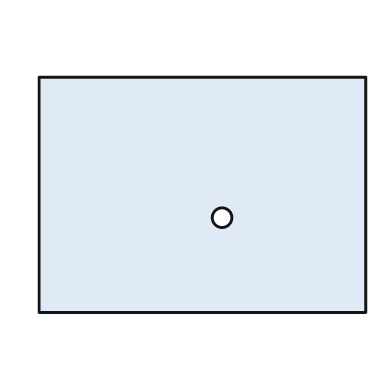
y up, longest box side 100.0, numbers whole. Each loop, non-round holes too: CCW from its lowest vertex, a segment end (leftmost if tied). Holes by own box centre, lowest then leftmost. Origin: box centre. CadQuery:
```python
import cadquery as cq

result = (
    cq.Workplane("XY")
    .moveTo(-50.0, -36.0)
    .lineTo(50.0, -36.0)
    .lineTo(50.0, 36.0)
    .lineTo(-50.0, 36.0)
    .close()
    .moveTo(6.0, -7.0)
    .circle(3.0)
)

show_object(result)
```